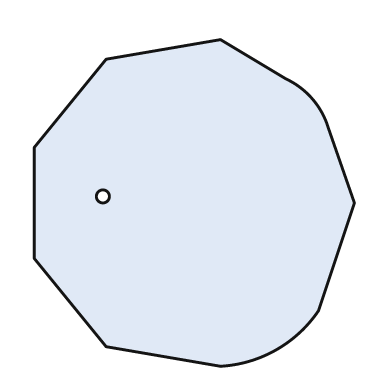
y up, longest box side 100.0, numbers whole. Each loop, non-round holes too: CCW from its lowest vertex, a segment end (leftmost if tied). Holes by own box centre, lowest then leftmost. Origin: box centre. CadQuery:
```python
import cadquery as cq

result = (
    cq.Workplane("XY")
    .moveTo(8.0, -50.0)
    .threePointArc((25.0, -45.0), (38.0, -33.0))
    .lineTo(49.0, 0.0)
    .lineTo(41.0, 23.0)
    .threePointArc((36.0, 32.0), (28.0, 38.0))
    .lineTo(8.0, 50.0)
    .lineTo(-27.0, 44.0)
    .lineTo(-49.0, 17.0)
    .lineTo(-49.0, -17.0)
    .lineTo(-27.0, -44.0)
    .close()
    .moveTo(-28.0, 2.0)
    .circle(2.0)
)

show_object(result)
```